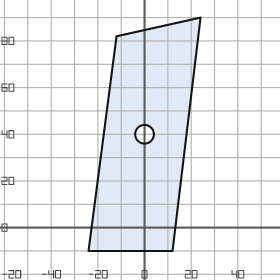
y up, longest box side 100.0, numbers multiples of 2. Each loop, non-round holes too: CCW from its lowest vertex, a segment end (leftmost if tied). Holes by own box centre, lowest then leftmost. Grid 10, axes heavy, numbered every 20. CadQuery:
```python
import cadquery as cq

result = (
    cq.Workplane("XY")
    .moveTo(-24.0, -10.0)
    .lineTo(12.0, -10.0)
    .lineTo(24.0, 90.0)
    .lineTo(-12.0, 82.0)
    .close()
    .moveTo(0.0, 40.0)
    .circle(4.0)
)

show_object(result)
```